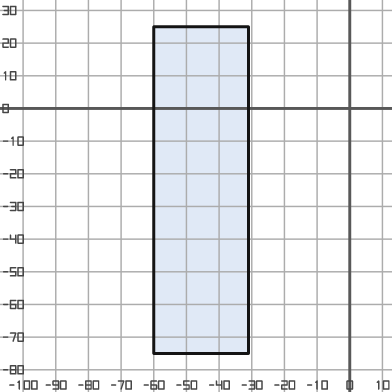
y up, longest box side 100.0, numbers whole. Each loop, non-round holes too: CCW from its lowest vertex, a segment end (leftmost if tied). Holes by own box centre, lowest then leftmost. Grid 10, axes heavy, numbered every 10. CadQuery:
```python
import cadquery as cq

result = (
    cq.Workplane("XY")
    .moveTo(-60.0, -75.0)
    .lineTo(-31.0, -75.0)
    .lineTo(-31.0, 25.0)
    .lineTo(-60.0, 25.0)
    .close()
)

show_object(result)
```